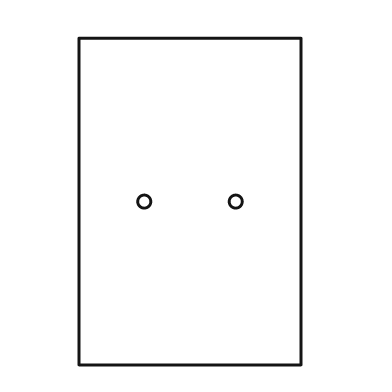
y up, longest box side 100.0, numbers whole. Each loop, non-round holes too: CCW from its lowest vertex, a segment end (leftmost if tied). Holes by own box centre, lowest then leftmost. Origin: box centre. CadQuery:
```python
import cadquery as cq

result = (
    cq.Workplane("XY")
    .moveTo(-34.0, -50.0)
    .lineTo(34.0, -50.0)
    .lineTo(34.0, 50.0)
    .lineTo(-34.0, 50.0)
    .close()
    .moveTo(-14.0, 0.0)
    .circle(2.0)
    .moveTo(14.0, 0.0)
    .circle(2.0)
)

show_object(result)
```